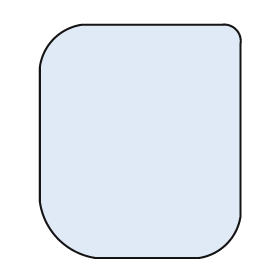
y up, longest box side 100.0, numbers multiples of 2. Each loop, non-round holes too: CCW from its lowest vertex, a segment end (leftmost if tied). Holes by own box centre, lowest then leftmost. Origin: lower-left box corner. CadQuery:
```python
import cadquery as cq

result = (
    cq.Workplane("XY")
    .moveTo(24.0, 0.0)
    .lineTo(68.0, 0.0)
    .threePointArc((80.0, 6.0), (86.0, 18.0))
    .lineTo(86.0, 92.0)
    .threePointArc((84.0, 98.0), (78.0, 100.0))
    .lineTo(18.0, 100.0)
    .threePointArc((6.0, 94.0), (0.0, 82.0))
    .lineTo(0.0, 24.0)
    .threePointArc((8.0, 8.0), (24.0, 0.0))
    .close()
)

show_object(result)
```